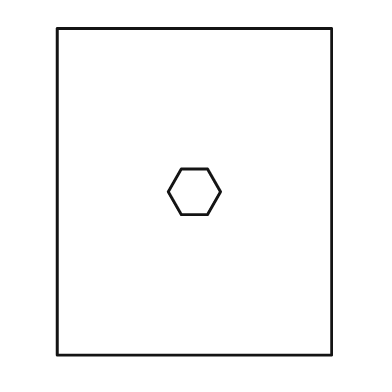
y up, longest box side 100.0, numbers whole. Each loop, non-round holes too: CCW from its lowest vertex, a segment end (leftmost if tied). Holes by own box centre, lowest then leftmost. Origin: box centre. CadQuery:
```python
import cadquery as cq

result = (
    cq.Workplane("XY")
    .moveTo(-42.0, -50.0)
    .lineTo(42.0, -50.0)
    .lineTo(42.0, 50.0)
    .lineTo(-42.0, 50.0)
    .close()
    .moveTo(-4.0, -7.0)
    .lineTo(4.0, -7.0)
    .lineTo(8.0, 0.0)
    .lineTo(4.0, 7.0)
    .lineTo(-4.0, 7.0)
    .lineTo(-8.0, 0.0)
    .close()
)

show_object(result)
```